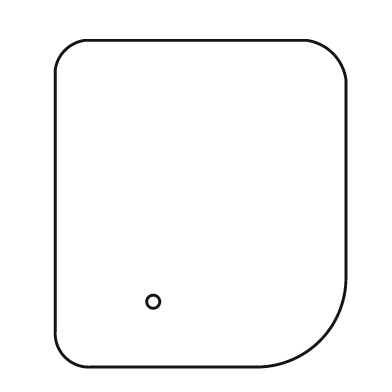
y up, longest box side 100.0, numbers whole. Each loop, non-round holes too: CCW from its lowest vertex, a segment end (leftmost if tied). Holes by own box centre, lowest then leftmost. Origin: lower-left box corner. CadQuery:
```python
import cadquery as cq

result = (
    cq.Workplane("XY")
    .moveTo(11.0, 0.0)
    .lineTo(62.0, 0.0)
    .threePointArc((81.0, 8.0), (89.0, 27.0))
    .lineTo(89.0, 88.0)
    .threePointArc((85.0, 96.0), (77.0, 100.0))
    .lineTo(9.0, 100.0)
    .threePointArc((3.0, 97.0), (0.0, 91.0))
    .lineTo(0.0, 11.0)
    .threePointArc((3.0, 3.0), (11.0, 0.0))
    .close()
    .moveTo(30.0, 20.0)
    .circle(2.0)
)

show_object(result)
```